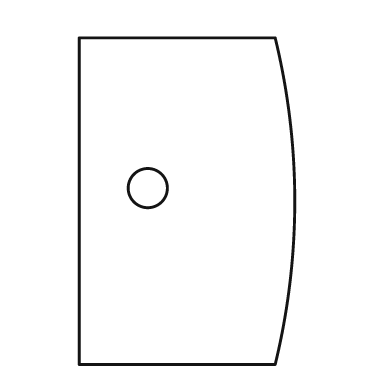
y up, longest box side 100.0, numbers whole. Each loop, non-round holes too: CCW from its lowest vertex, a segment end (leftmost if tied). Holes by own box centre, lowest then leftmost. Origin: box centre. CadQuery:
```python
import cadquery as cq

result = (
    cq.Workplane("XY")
    .moveTo(-33.0, -50.0)
    .lineTo(27.0, -50.0)
    .threePointArc((33.0, 0.0), (27.0, 50.0))
    .lineTo(-33.0, 50.0)
    .close()
    .moveTo(-12.0, 4.0)
    .circle(6.0)
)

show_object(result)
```